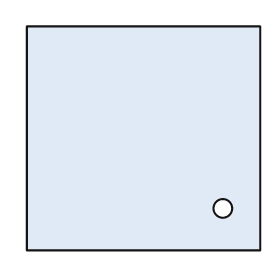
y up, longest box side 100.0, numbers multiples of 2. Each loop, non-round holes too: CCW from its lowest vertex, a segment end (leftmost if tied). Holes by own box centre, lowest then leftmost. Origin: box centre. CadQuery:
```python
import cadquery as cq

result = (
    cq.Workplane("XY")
    .moveTo(-50.0, -48.0)
    .lineTo(50.0, -48.0)
    .lineTo(50.0, 48.0)
    .lineTo(-50.0, 48.0)
    .close()
    .moveTo(34.0, -30.0)
    .circle(4.0)
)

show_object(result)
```